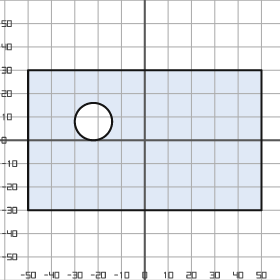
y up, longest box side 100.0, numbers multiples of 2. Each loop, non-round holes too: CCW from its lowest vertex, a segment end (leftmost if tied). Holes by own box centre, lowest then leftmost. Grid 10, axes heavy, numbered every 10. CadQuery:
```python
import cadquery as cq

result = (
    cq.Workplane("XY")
    .moveTo(-50.0, -30.0)
    .lineTo(50.0, -30.0)
    .lineTo(50.0, 30.0)
    .lineTo(-50.0, 30.0)
    .close()
    .moveTo(-22.0, 8.0)
    .circle(8.0)
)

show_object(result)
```